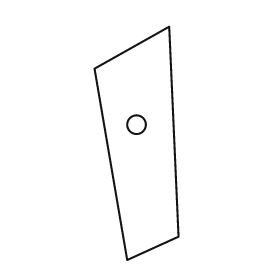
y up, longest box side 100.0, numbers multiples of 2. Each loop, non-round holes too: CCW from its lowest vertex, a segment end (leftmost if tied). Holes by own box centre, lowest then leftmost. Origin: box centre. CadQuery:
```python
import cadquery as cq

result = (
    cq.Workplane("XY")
    .moveTo(-4.0, -50.0)
    .lineTo(18.0, -40.0)
    .lineTo(14.0, 50.0)
    .lineTo(-18.0, 32.0)
    .close()
    .moveTo(0.0, 8.0)
    .circle(4.0)
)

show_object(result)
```